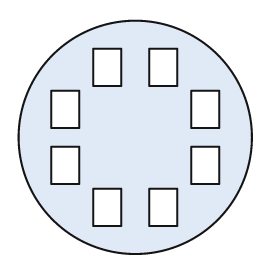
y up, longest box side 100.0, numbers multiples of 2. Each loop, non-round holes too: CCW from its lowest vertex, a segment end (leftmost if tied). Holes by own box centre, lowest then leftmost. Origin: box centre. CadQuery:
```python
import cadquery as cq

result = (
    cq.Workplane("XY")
    .moveTo(0.0, 0.0)
    .circle(50.0)
    .moveTo(-18.0, -38.0)
    .lineTo(-6.0, -38.0)
    .lineTo(-6.0, -22.0)
    .lineTo(-18.0, -22.0)
    .close()
    .moveTo(6.0, -38.0)
    .lineTo(18.0, -38.0)
    .lineTo(18.0, -22.0)
    .lineTo(6.0, -22.0)
    .close()
    .moveTo(-36.0, -20.0)
    .lineTo(-24.0, -20.0)
    .lineTo(-24.0, -4.0)
    .lineTo(-36.0, -4.0)
    .close()
    .moveTo(24.0, -20.0)
    .lineTo(36.0, -20.0)
    .lineTo(36.0, -4.0)
    .lineTo(24.0, -4.0)
    .close()
    .moveTo(-36.0, 4.0)
    .lineTo(-24.0, 4.0)
    .lineTo(-24.0, 20.0)
    .lineTo(-36.0, 20.0)
    .close()
    .moveTo(24.0, 4.0)
    .lineTo(36.0, 4.0)
    .lineTo(36.0, 20.0)
    .lineTo(24.0, 20.0)
    .close()
    .moveTo(-18.0, 22.0)
    .lineTo(-6.0, 22.0)
    .lineTo(-6.0, 38.0)
    .lineTo(-18.0, 38.0)
    .close()
    .moveTo(6.0, 22.0)
    .lineTo(18.0, 22.0)
    .lineTo(18.0, 38.0)
    .lineTo(6.0, 38.0)
    .close()
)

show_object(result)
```